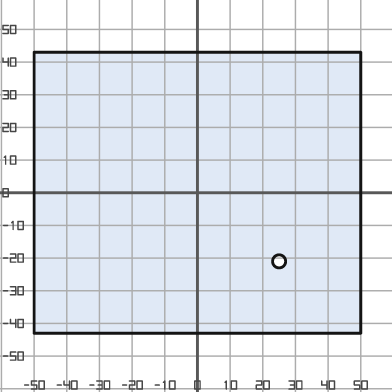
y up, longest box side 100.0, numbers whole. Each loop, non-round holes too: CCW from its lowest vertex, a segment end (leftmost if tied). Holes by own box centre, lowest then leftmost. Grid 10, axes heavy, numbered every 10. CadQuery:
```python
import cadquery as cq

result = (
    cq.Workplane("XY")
    .moveTo(-50.0, -43.0)
    .lineTo(50.0, -43.0)
    .lineTo(50.0, 43.0)
    .lineTo(-50.0, 43.0)
    .close()
    .moveTo(25.0, -21.0)
    .circle(2.0)
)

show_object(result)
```